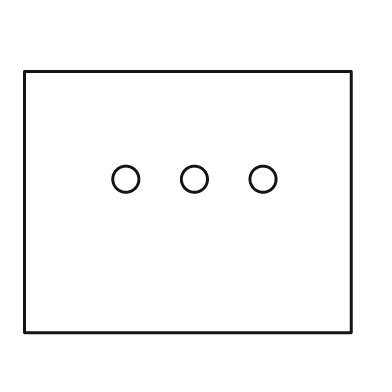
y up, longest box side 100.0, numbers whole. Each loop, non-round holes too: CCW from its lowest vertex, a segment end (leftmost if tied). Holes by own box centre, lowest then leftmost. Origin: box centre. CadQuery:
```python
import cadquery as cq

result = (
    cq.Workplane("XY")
    .moveTo(-50.0, -40.0)
    .lineTo(50.0, -40.0)
    .lineTo(50.0, 40.0)
    .lineTo(-50.0, 40.0)
    .close()
    .moveTo(-19.0, 7.0)
    .circle(4.0)
    .moveTo(2.0, 7.0)
    .circle(4.0)
    .moveTo(23.0, 7.0)
    .circle(4.0)
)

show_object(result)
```